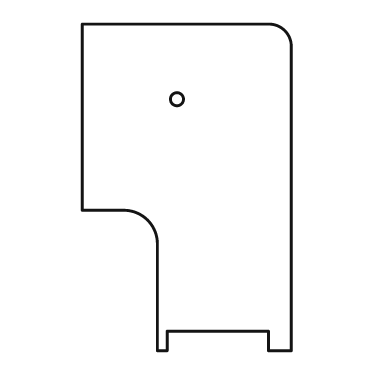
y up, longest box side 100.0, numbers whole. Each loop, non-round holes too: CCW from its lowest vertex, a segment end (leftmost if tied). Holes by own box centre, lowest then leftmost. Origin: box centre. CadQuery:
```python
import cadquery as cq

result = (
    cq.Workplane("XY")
    .moveTo(-9.0, -50.0)
    .lineTo(-6.0, -50.0)
    .lineTo(-6.0, -44.0)
    .lineTo(25.0, -44.0)
    .lineTo(25.0, -50.0)
    .lineTo(32.0, -50.0)
    .lineTo(32.0, 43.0)
    .threePointArc((30.0, 48.0), (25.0, 50.0))
    .lineTo(-32.0, 50.0)
    .lineTo(-32.0, -7.0)
    .lineTo(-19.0, -7.0)
    .threePointArc((-12.0, -10.0), (-9.0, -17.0))
    .close()
    .moveTo(-3.0, 27.0)
    .circle(2.0)
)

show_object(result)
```